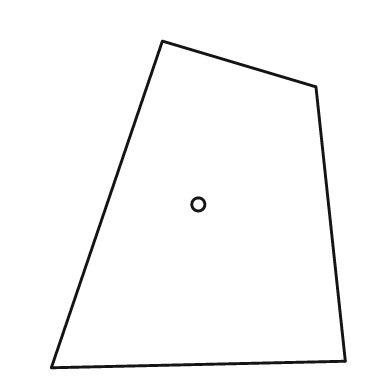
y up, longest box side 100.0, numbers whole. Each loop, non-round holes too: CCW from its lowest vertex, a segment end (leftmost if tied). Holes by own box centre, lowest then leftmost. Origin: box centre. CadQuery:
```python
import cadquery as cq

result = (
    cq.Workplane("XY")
    .moveTo(-45.0, -50.0)
    .lineTo(45.0, -48.0)
    .lineTo(36.0, 36.0)
    .lineTo(-11.0, 50.0)
    .close()
    .moveTo(0.0, 0.0)
    .circle(2.0)
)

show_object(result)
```